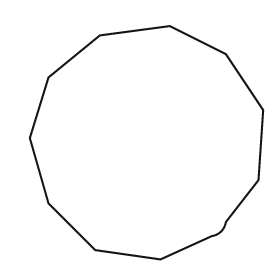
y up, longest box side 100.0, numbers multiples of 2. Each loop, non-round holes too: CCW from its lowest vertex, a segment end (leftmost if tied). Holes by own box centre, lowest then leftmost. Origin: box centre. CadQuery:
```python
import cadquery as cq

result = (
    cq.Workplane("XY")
    .moveTo(6.0, -50.0)
    .lineTo(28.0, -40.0)
    .threePointArc((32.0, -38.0), (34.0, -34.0))
    .lineTo(48.0, -16.0)
    .lineTo(50.0, 14.0)
    .lineTo(34.0, 38.0)
    .lineTo(10.0, 50.0)
    .lineTo(-20.0, 46.0)
    .lineTo(-42.0, 28.0)
    .lineTo(-50.0, 2.0)
    .lineTo(-42.0, -26.0)
    .lineTo(-22.0, -46.0)
    .close()
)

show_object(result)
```